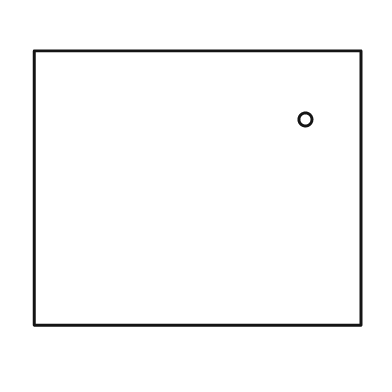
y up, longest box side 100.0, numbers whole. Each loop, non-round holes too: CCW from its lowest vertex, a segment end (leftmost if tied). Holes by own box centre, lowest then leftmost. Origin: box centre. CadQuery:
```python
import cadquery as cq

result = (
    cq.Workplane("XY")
    .moveTo(-50.0, -42.0)
    .lineTo(50.0, -42.0)
    .lineTo(50.0, 42.0)
    .lineTo(-50.0, 42.0)
    .close()
    .moveTo(33.0, 21.0)
    .circle(2.0)
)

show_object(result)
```